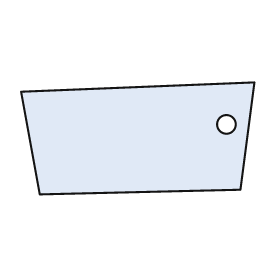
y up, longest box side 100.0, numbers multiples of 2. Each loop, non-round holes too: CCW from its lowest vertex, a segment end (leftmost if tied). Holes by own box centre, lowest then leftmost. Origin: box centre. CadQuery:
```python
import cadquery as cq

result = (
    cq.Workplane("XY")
    .moveTo(-42.0, -24.0)
    .lineTo(44.0, -22.0)
    .lineTo(50.0, 24.0)
    .lineTo(-50.0, 20.0)
    .close()
    .moveTo(38.0, 6.0)
    .circle(4.0)
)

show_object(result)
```